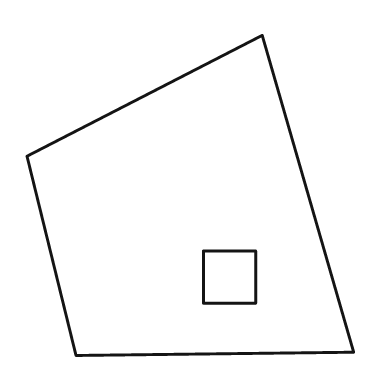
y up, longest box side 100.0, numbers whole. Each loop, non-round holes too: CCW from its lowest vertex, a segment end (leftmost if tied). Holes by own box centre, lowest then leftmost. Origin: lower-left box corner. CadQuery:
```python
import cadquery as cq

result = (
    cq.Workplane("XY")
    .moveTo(15.0, 0.0)
    .lineTo(100.0, 1.0)
    .lineTo(72.0, 98.0)
    .lineTo(0.0, 61.0)
    .close()
    .moveTo(54.0, 16.0)
    .lineTo(70.0, 16.0)
    .lineTo(70.0, 32.0)
    .lineTo(54.0, 32.0)
    .close()
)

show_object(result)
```